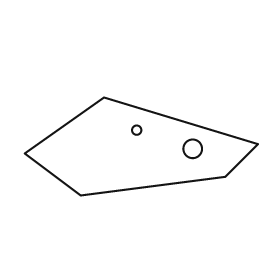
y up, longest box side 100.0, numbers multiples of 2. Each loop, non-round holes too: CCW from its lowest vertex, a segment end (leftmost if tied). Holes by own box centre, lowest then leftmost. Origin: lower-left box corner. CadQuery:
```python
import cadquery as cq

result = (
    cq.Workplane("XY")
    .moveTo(24.0, 0.0)
    .lineTo(86.0, 8.0)
    .lineTo(100.0, 22.0)
    .lineTo(34.0, 42.0)
    .lineTo(0.0, 18.0)
    .close()
    .moveTo(72.0, 20.0)
    .circle(4.0)
    .moveTo(48.0, 28.0)
    .circle(2.0)
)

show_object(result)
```